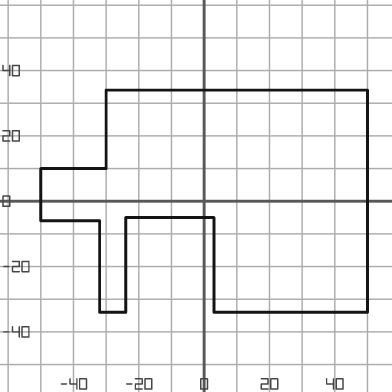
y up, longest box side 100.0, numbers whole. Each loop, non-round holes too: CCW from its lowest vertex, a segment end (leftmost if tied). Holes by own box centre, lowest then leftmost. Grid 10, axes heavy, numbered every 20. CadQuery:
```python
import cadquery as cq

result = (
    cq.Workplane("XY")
    .moveTo(-32.0, -34.0)
    .lineTo(-24.0, -34.0)
    .lineTo(-24.0, -5.0)
    .lineTo(3.0, -5.0)
    .lineTo(3.0, -34.0)
    .lineTo(50.0, -34.0)
    .lineTo(50.0, 34.0)
    .lineTo(-30.0, 34.0)
    .lineTo(-30.0, 10.0)
    .lineTo(-50.0, 10.0)
    .lineTo(-50.0, -6.0)
    .lineTo(-32.0, -6.0)
    .close()
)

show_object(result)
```